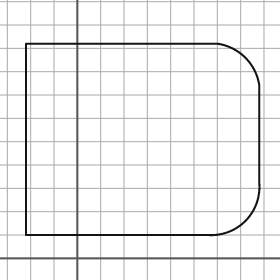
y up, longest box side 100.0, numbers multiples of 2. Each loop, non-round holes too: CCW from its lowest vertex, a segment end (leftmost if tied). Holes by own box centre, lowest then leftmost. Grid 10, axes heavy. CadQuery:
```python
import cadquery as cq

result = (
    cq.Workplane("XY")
    .moveTo(-22.0, 10.0)
    .lineTo(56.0, 10.0)
    .threePointArc((72.0, 16.0), (78.0, 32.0))
    .lineTo(78.0, 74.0)
    .threePointArc((72.0, 86.0), (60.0, 92.0))
    .lineTo(-22.0, 92.0)
    .close()
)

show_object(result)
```